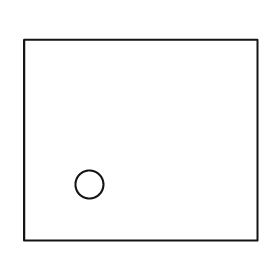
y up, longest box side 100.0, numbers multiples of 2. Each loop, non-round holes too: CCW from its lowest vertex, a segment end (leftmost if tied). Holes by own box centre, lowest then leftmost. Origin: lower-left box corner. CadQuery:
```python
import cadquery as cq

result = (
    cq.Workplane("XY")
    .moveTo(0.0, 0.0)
    .lineTo(100.0, 0.0)
    .lineTo(100.0, 86.0)
    .lineTo(0.0, 86.0)
    .close()
    .moveTo(28.0, 24.0)
    .circle(6.0)
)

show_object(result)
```